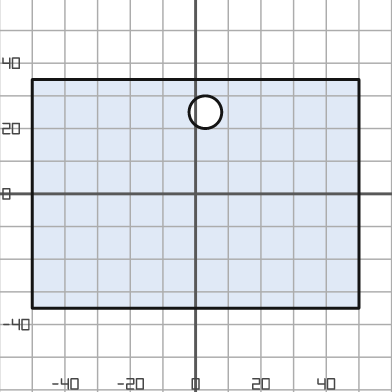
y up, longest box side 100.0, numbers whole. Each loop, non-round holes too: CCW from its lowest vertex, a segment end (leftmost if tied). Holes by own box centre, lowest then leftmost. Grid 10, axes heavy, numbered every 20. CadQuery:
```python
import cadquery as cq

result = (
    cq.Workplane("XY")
    .moveTo(-50.0, -35.0)
    .lineTo(50.0, -35.0)
    .lineTo(50.0, 35.0)
    .lineTo(-50.0, 35.0)
    .close()
    .moveTo(3.0, 25.0)
    .circle(5.0)
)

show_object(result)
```